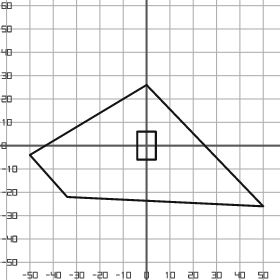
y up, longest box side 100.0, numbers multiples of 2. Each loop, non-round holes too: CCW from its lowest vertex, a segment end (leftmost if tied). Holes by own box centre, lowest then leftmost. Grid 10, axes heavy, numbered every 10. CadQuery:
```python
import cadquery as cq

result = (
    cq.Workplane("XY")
    .moveTo(50.0, -26.0)
    .lineTo(0.0, 26.0)
    .lineTo(-50.0, -4.0)
    .lineTo(-34.0, -22.0)
    .close()
    .moveTo(-4.0, -6.0)
    .lineTo(4.0, -6.0)
    .lineTo(4.0, 6.0)
    .lineTo(-4.0, 6.0)
    .close()
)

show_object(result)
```